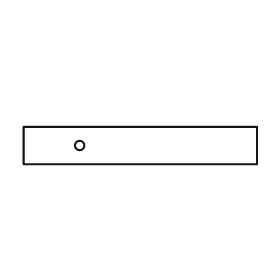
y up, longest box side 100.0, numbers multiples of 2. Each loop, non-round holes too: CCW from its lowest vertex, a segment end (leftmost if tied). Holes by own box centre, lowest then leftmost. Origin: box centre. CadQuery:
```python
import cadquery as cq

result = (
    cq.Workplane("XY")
    .moveTo(-50.0, -8.0)
    .lineTo(50.0, -8.0)
    .lineTo(50.0, 8.0)
    .lineTo(-50.0, 8.0)
    .close()
    .moveTo(-26.0, 0.0)
    .circle(2.0)
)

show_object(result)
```